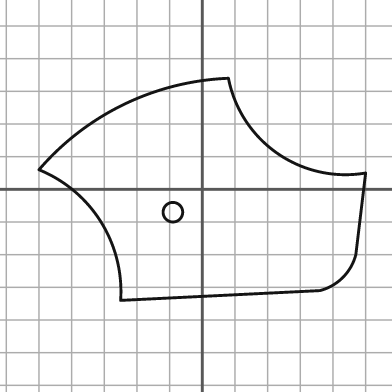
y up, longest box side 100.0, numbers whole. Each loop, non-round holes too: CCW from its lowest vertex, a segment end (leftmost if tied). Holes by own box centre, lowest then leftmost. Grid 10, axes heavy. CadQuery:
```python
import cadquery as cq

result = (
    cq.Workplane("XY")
    .moveTo(-25.0, -34.0)
    .lineTo(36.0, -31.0)
    .threePointArc((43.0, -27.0), (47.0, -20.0))
    .lineTo(50.0, 5.0)
    .threePointArc((23.0, 11.0), (8.0, 34.0))
    .threePointArc((-24.0, 26.0), (-50.0, 6.0))
    .threePointArc((-31.0, -10.0), (-25.0, -34.0))
    .close()
    .moveTo(-9.0, -7.0)
    .circle(3.0)
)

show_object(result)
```